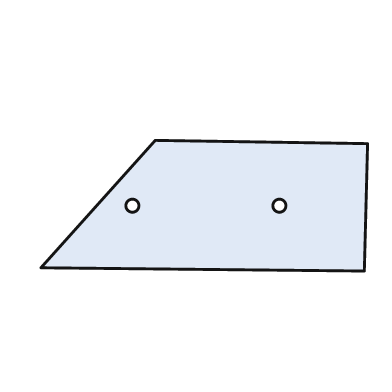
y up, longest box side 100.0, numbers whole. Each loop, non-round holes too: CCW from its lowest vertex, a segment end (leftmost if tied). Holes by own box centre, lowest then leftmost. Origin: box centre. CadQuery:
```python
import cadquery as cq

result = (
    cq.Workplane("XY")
    .moveTo(49.0, -20.0)
    .lineTo(50.0, 19.0)
    .lineTo(-15.0, 20.0)
    .lineTo(-50.0, -19.0)
    .close()
    .moveTo(-22.0, 0.0)
    .circle(2.0)
    .moveTo(23.0, 0.0)
    .circle(2.0)
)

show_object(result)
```